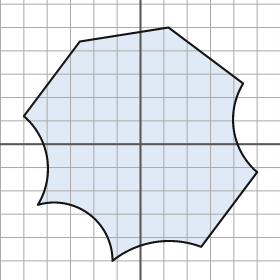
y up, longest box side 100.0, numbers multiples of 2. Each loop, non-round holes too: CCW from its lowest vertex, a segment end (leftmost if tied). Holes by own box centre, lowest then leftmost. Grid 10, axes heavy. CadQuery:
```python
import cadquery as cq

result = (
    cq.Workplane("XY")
    .moveTo(-12.0, -50.0)
    .threePointArc((6.0, -42.0), (26.0, -44.0))
    .lineTo(50.0, -12.0)
    .threePointArc((40.0, 6.0), (44.0, 26.0))
    .lineTo(12.0, 50.0)
    .lineTo(-26.0, 44.0)
    .lineTo(-50.0, 12.0)
    .threePointArc((-40.0, -6.0), (-44.0, -26.0))
    .threePointArc((-22.0, -30.0), (-12.0, -50.0))
    .close()
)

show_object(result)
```